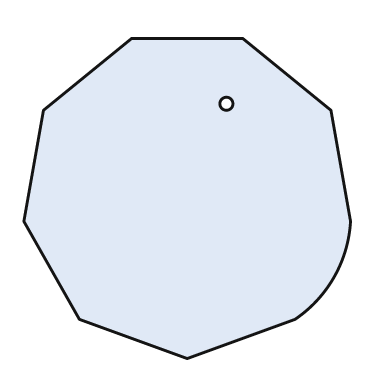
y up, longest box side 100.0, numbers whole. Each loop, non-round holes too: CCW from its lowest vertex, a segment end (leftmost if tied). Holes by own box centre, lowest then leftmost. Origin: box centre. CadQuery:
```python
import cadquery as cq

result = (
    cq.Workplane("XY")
    .moveTo(0.0, -49.0)
    .lineTo(33.0, -37.0)
    .threePointArc((45.0, -24.0), (50.0, -7.0))
    .lineTo(44.0, 27.0)
    .lineTo(17.0, 49.0)
    .lineTo(-17.0, 49.0)
    .lineTo(-44.0, 27.0)
    .lineTo(-50.0, -7.0)
    .lineTo(-33.0, -37.0)
    .close()
    .moveTo(12.0, 29.0)
    .circle(2.0)
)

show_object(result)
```